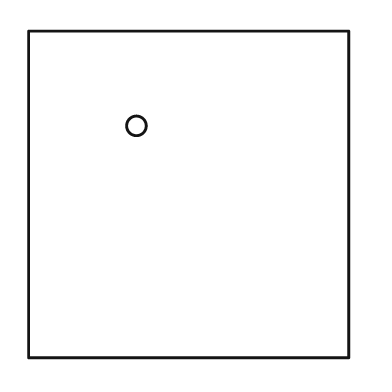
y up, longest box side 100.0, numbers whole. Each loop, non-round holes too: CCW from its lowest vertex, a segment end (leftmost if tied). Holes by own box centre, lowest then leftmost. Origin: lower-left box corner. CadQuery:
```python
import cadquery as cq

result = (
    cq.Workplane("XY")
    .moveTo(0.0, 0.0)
    .lineTo(98.0, 0.0)
    .lineTo(98.0, 100.0)
    .lineTo(0.0, 100.0)
    .close()
    .moveTo(33.0, 71.0)
    .circle(3.0)
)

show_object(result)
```